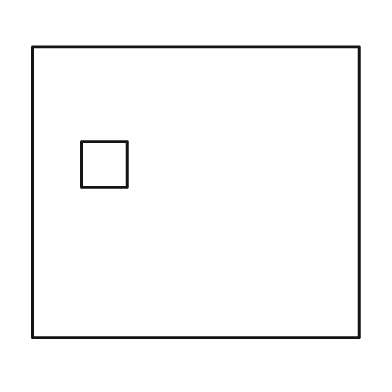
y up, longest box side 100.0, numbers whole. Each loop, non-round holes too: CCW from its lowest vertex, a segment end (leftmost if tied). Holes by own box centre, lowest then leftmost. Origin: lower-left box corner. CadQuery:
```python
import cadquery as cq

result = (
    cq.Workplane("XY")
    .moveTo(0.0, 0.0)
    .lineTo(100.0, 0.0)
    .lineTo(100.0, 89.0)
    .lineTo(0.0, 89.0)
    .close()
    .moveTo(15.0, 46.0)
    .lineTo(29.0, 46.0)
    .lineTo(29.0, 60.0)
    .lineTo(15.0, 60.0)
    .close()
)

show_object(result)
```